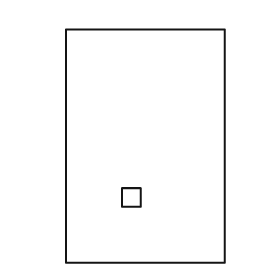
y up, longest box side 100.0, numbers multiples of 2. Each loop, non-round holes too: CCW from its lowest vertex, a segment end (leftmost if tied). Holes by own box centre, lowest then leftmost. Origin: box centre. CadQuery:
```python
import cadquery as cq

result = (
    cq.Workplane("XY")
    .moveTo(-34.0, -50.0)
    .lineTo(34.0, -50.0)
    .lineTo(34.0, 50.0)
    .lineTo(-34.0, 50.0)
    .close()
    .moveTo(-10.0, -26.0)
    .lineTo(-2.0, -26.0)
    .lineTo(-2.0, -18.0)
    .lineTo(-10.0, -18.0)
    .close()
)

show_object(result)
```